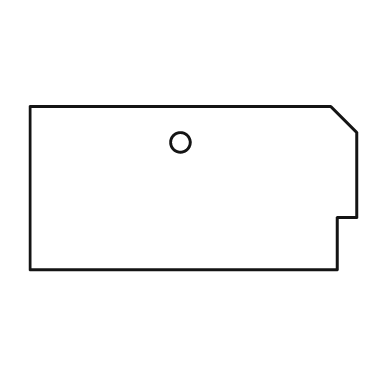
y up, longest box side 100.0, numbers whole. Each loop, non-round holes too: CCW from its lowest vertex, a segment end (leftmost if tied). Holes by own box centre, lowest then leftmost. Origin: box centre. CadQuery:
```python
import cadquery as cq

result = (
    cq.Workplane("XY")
    .moveTo(-50.0, -25.0)
    .lineTo(44.0, -25.0)
    .lineTo(44.0, -9.0)
    .lineTo(50.0, -9.0)
    .lineTo(50.0, 17.0)
    .lineTo(42.0, 25.0)
    .lineTo(-50.0, 25.0)
    .close()
    .moveTo(-4.0, 14.0)
    .circle(3.0)
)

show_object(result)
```